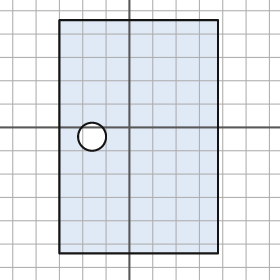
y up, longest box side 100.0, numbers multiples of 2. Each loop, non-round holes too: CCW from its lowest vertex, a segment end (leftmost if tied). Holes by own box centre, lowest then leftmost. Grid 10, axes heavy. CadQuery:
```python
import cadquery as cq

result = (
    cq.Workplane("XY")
    .moveTo(-30.0, -54.0)
    .lineTo(38.0, -54.0)
    .lineTo(38.0, 46.0)
    .lineTo(-30.0, 46.0)
    .close()
    .moveTo(-16.0, -4.0)
    .circle(6.0)
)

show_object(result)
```